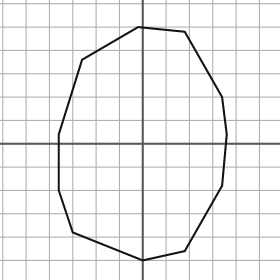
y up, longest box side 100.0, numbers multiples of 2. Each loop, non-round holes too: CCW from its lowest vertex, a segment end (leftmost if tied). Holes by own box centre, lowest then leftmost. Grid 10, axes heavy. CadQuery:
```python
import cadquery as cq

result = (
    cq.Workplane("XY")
    .moveTo(0.0, -50.0)
    .lineTo(18.0, -46.0)
    .lineTo(34.0, -18.0)
    .lineTo(36.0, 4.0)
    .lineTo(34.0, 20.0)
    .lineTo(18.0, 48.0)
    .lineTo(-2.0, 50.0)
    .lineTo(-26.0, 36.0)
    .lineTo(-36.0, 4.0)
    .lineTo(-36.0, -20.0)
    .lineTo(-30.0, -38.0)
    .close()
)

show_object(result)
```